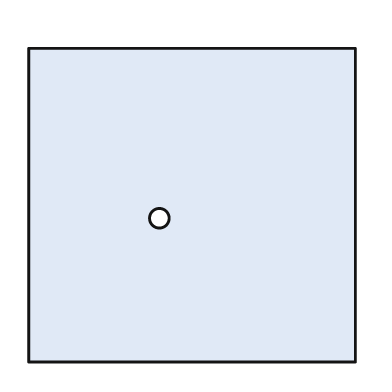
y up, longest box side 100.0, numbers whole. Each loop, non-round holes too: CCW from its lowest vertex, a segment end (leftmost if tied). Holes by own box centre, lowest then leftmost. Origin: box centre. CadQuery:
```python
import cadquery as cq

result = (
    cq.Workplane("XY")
    .moveTo(-50.0, -48.0)
    .lineTo(50.0, -48.0)
    .lineTo(50.0, 48.0)
    .lineTo(-50.0, 48.0)
    .close()
    .moveTo(-10.0, -4.0)
    .circle(3.0)
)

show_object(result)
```